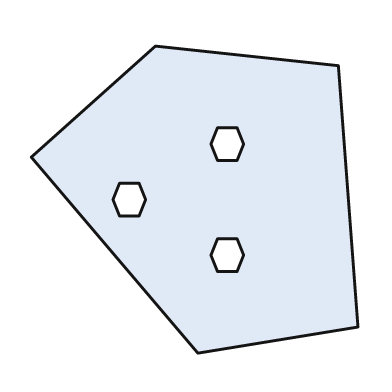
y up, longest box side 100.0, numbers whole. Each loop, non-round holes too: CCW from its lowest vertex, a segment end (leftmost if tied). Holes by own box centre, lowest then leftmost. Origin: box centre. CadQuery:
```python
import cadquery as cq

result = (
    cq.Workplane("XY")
    .moveTo(1.0, -47.0)
    .lineTo(50.0, -39.0)
    .lineTo(44.0, 41.0)
    .lineTo(-12.0, 47.0)
    .lineTo(-50.0, 13.0)
    .close()
    .moveTo(7.0, -22.0)
    .lineTo(13.0, -22.0)
    .lineTo(15.0, -17.0)
    .lineTo(13.0, -12.0)
    .lineTo(7.0, -12.0)
    .lineTo(5.0, -17.0)
    .close()
    .moveTo(-23.0, -5.0)
    .lineTo(-17.0, -5.0)
    .lineTo(-15.0, 0.0)
    .lineTo(-17.0, 5.0)
    .lineTo(-23.0, 5.0)
    .lineTo(-25.0, 0.0)
    .close()
    .moveTo(7.0, 12.0)
    .lineTo(13.0, 12.0)
    .lineTo(15.0, 17.0)
    .lineTo(13.0, 22.0)
    .lineTo(7.0, 22.0)
    .lineTo(5.0, 17.0)
    .close()
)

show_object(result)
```